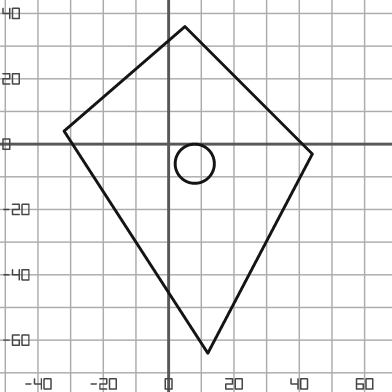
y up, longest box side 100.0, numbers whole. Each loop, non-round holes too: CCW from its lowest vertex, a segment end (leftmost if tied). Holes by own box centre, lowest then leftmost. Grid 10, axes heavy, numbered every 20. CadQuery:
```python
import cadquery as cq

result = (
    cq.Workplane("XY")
    .moveTo(12.0, -64.0)
    .lineTo(44.0, -3.0)
    .lineTo(5.0, 36.0)
    .lineTo(-32.0, 4.0)
    .close()
    .moveTo(8.0, -6.0)
    .circle(6.0)
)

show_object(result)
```